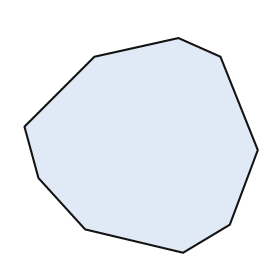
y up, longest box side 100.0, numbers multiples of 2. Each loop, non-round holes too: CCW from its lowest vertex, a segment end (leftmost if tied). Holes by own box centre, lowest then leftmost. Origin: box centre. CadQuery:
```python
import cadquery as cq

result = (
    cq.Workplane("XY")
    .moveTo(18.0, -46.0)
    .lineTo(38.0, -34.0)
    .lineTo(50.0, -2.0)
    .lineTo(34.0, 38.0)
    .lineTo(16.0, 46.0)
    .lineTo(-20.0, 38.0)
    .lineTo(-50.0, 8.0)
    .lineTo(-44.0, -14.0)
    .lineTo(-24.0, -36.0)
    .close()
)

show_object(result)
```